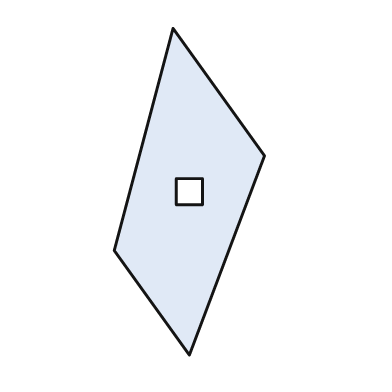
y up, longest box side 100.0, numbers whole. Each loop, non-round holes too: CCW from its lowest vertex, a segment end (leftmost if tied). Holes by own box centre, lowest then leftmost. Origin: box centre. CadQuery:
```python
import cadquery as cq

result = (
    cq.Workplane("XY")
    .moveTo(0.0, -50.0)
    .lineTo(23.0, 11.0)
    .lineTo(-5.0, 50.0)
    .lineTo(-23.0, -18.0)
    .close()
    .moveTo(-4.0, -4.0)
    .lineTo(4.0, -4.0)
    .lineTo(4.0, 4.0)
    .lineTo(-4.0, 4.0)
    .close()
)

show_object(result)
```